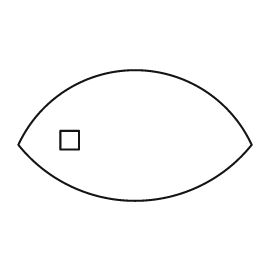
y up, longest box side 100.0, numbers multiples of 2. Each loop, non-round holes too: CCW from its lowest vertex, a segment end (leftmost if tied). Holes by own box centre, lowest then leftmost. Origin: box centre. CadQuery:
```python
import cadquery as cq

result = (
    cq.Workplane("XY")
    .moveTo(-50.0, -4.0)
    .threePointArc((0.0, -28.0), (50.0, -4.0))
    .threePointArc((0.0, 28.0), (-50.0, -4.0))
    .close()
    .moveTo(-32.0, -6.0)
    .lineTo(-24.0, -6.0)
    .lineTo(-24.0, 2.0)
    .lineTo(-32.0, 2.0)
    .close()
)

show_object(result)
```